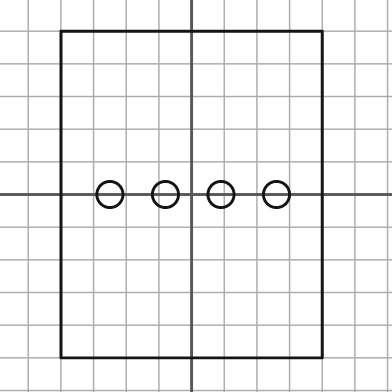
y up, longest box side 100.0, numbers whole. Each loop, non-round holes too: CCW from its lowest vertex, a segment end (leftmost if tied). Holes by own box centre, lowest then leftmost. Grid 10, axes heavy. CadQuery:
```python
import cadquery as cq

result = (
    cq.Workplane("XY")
    .moveTo(-40.0, -50.0)
    .lineTo(40.0, -50.0)
    .lineTo(40.0, 50.0)
    .lineTo(-40.0, 50.0)
    .close()
    .moveTo(-25.0, 0.0)
    .circle(4.0)
    .moveTo(-8.0, 0.0)
    .circle(4.0)
    .moveTo(9.0, 0.0)
    .circle(4.0)
    .moveTo(26.0, 0.0)
    .circle(4.0)
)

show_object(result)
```